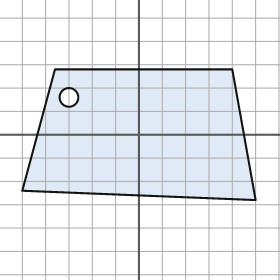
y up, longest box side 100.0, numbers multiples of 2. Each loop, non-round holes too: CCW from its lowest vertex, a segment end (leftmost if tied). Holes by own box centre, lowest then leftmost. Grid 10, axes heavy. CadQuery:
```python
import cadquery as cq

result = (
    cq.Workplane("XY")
    .moveTo(50.0, -28.0)
    .lineTo(40.0, 28.0)
    .lineTo(-36.0, 28.0)
    .lineTo(-50.0, -24.0)
    .close()
    .moveTo(-30.0, 16.0)
    .circle(4.0)
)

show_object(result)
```